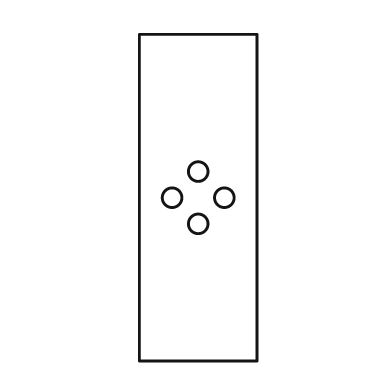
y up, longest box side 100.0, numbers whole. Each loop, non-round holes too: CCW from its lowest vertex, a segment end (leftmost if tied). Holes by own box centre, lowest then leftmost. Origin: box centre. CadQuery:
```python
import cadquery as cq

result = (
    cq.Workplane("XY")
    .moveTo(-18.0, -50.0)
    .lineTo(18.0, -50.0)
    .lineTo(18.0, 50.0)
    .lineTo(-18.0, 50.0)
    .close()
    .moveTo(0.0, -8.0)
    .circle(3.0)
    .moveTo(-8.0, 0.0)
    .circle(3.0)
    .moveTo(8.0, 0.0)
    .circle(3.0)
    .moveTo(0.0, 8.0)
    .circle(3.0)
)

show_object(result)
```